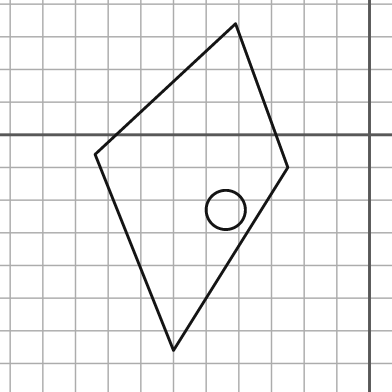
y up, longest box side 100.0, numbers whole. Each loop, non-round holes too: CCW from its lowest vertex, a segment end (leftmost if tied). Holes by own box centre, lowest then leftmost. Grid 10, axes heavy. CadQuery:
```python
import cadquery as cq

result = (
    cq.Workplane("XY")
    .moveTo(-60.0, -66.0)
    .lineTo(-25.0, -10.0)
    .lineTo(-41.0, 34.0)
    .lineTo(-84.0, -6.0)
    .close()
    .moveTo(-44.0, -23.0)
    .circle(6.0)
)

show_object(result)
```